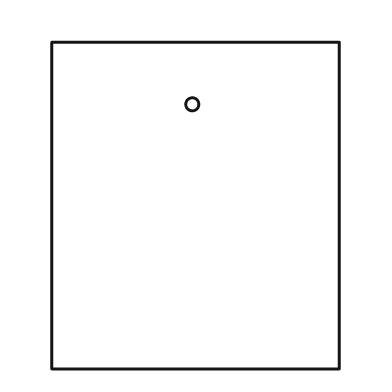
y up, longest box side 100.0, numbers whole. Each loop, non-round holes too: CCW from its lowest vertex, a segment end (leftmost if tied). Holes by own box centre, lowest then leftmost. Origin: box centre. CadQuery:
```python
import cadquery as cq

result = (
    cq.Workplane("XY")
    .moveTo(-44.0, -50.0)
    .lineTo(44.0, -50.0)
    .lineTo(44.0, 50.0)
    .lineTo(-44.0, 50.0)
    .close()
    .moveTo(-1.0, 31.0)
    .circle(2.0)
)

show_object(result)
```